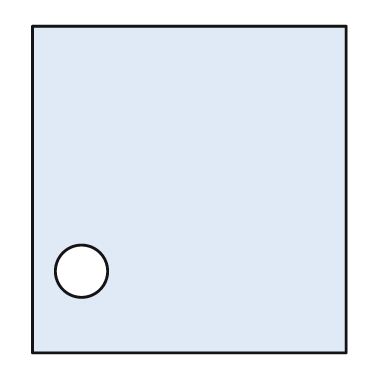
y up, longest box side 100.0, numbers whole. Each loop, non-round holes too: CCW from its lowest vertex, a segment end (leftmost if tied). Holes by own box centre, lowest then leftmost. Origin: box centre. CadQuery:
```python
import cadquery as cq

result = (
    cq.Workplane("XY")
    .moveTo(-48.0, -50.0)
    .lineTo(48.0, -50.0)
    .lineTo(48.0, 50.0)
    .lineTo(-48.0, 50.0)
    .close()
    .moveTo(-33.0, -25.0)
    .circle(8.0)
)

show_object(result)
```